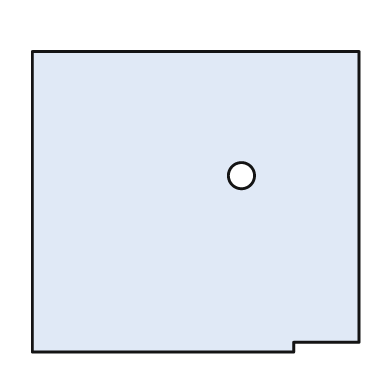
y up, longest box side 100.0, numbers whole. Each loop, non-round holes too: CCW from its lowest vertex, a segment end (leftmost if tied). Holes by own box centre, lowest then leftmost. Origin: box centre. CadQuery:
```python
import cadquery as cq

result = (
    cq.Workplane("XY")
    .moveTo(-50.0, -46.0)
    .lineTo(30.0, -46.0)
    .lineTo(30.0, -43.0)
    .lineTo(50.0, -43.0)
    .lineTo(50.0, 46.0)
    .lineTo(-50.0, 46.0)
    .close()
    .moveTo(14.0, 8.0)
    .circle(4.0)
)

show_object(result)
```